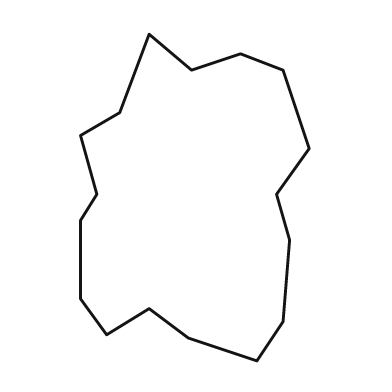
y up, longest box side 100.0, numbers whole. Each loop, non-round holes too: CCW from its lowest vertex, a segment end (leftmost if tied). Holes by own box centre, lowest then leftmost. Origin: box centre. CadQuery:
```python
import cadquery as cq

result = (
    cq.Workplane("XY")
    .moveTo(19.0, -50.0)
    .lineTo(27.0, -38.0)
    .lineTo(29.0, -13.0)
    .lineTo(25.0, 1.0)
    .lineTo(35.0, 15.0)
    .lineTo(27.0, 39.0)
    .lineTo(14.0, 44.0)
    .lineTo(-1.0, 39.0)
    .lineTo(-14.0, 50.0)
    .lineTo(-23.0, 26.0)
    .lineTo(-35.0, 19.0)
    .lineTo(-30.0, 1.0)
    .lineTo(-35.0, -7.0)
    .lineTo(-35.0, -31.0)
    .lineTo(-27.0, -42.0)
    .lineTo(-14.0, -34.0)
    .lineTo(-2.0, -43.0)
    .close()
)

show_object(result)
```